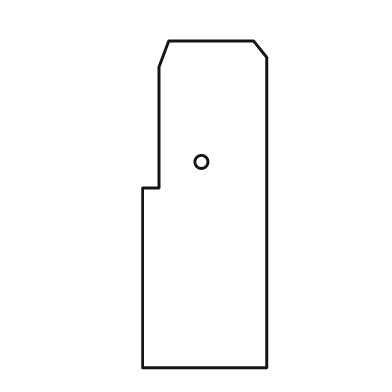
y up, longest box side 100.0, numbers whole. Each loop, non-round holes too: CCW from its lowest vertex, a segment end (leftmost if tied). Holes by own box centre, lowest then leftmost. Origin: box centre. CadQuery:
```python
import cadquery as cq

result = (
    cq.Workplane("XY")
    .moveTo(-19.0, -50.0)
    .lineTo(19.0, -50.0)
    .lineTo(19.0, 45.0)
    .lineTo(15.0, 50.0)
    .lineTo(-11.0, 50.0)
    .lineTo(-14.0, 42.0)
    .lineTo(-14.0, 5.0)
    .lineTo(-19.0, 5.0)
    .close()
    .moveTo(-1.0, 13.0)
    .circle(2.0)
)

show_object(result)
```